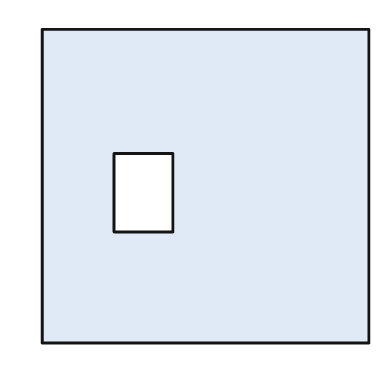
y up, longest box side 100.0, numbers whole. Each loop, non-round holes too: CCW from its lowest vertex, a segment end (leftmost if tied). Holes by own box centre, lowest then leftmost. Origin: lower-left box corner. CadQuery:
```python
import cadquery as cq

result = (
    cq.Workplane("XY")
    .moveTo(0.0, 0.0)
    .lineTo(100.0, 0.0)
    .lineTo(100.0, 96.0)
    .lineTo(0.0, 96.0)
    .close()
    .moveTo(22.0, 34.0)
    .lineTo(40.0, 34.0)
    .lineTo(40.0, 58.0)
    .lineTo(22.0, 58.0)
    .close()
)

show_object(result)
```